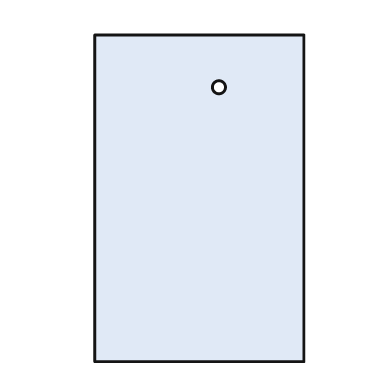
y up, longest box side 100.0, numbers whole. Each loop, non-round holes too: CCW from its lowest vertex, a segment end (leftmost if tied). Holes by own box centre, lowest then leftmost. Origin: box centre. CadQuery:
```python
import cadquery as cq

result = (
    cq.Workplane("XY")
    .moveTo(-32.0, -50.0)
    .lineTo(32.0, -50.0)
    .lineTo(32.0, 50.0)
    .lineTo(-32.0, 50.0)
    .close()
    .moveTo(6.0, 34.0)
    .circle(2.0)
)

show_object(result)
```